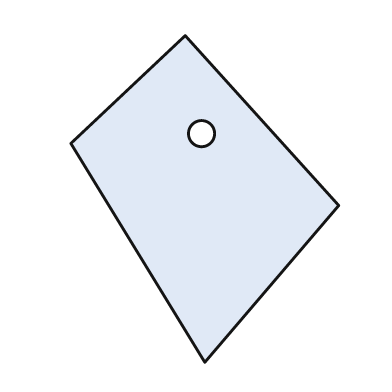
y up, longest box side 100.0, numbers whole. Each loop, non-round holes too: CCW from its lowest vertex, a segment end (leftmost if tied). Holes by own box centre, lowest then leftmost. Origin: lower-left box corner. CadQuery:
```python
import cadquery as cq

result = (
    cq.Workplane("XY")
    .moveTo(41.0, 0.0)
    .lineTo(82.0, 48.0)
    .lineTo(35.0, 100.0)
    .lineTo(0.0, 67.0)
    .close()
    .moveTo(40.0, 70.0)
    .circle(4.0)
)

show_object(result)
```